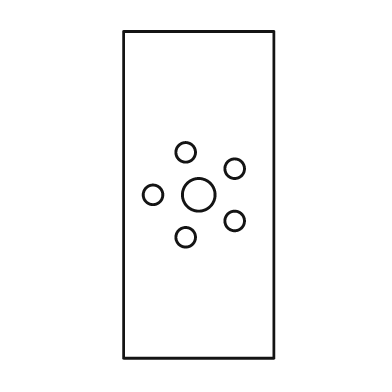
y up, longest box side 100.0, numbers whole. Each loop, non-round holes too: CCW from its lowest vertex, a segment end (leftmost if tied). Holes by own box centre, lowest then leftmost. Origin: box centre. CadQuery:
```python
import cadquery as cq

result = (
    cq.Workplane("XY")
    .moveTo(-23.0, -50.0)
    .lineTo(23.0, -50.0)
    .lineTo(23.0, 50.0)
    .lineTo(-23.0, 50.0)
    .close()
    .moveTo(-4.0, -13.0)
    .circle(3.0)
    .moveTo(11.0, -8.0)
    .circle(3.0)
    .moveTo(-14.0, 0.0)
    .circle(3.0)
    .moveTo(0.0, 0.0)
    .circle(5.0)
    .moveTo(11.0, 8.0)
    .circle(3.0)
    .moveTo(-4.0, 13.0)
    .circle(3.0)
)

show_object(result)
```